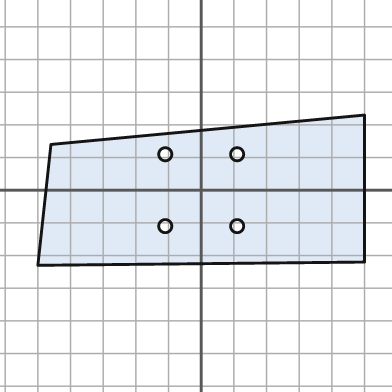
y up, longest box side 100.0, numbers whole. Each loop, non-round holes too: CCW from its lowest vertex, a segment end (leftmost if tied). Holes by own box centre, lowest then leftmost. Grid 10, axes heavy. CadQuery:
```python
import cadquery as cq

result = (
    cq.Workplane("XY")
    .moveTo(-50.0, -23.0)
    .lineTo(50.0, -22.0)
    .lineTo(50.0, 23.0)
    .lineTo(-46.0, 14.0)
    .close()
    .moveTo(-11.0, -11.0)
    .circle(2.0)
    .moveTo(11.0, -11.0)
    .circle(2.0)
    .moveTo(-11.0, 11.0)
    .circle(2.0)
    .moveTo(11.0, 11.0)
    .circle(2.0)
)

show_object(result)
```